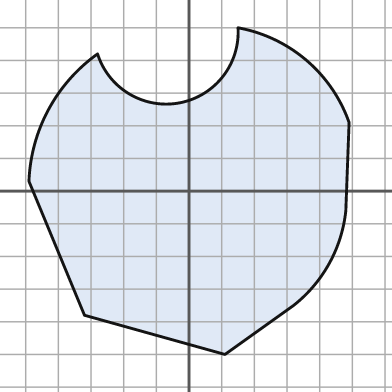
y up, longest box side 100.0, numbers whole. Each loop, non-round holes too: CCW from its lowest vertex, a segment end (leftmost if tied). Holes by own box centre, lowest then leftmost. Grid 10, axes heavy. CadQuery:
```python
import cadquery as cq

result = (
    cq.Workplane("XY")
    .moveTo(11.0, -50.0)
    .lineTo(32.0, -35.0)
    .threePointArc((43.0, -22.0), (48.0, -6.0))
    .lineTo(49.0, 21.0)
    .threePointArc((36.0, 40.0), (15.0, 50.0))
    .threePointArc((-3.0, 27.0), (-28.0, 42.0))
    .threePointArc((-43.0, 25.0), (-49.0, 3.0))
    .lineTo(-32.0, -38.0)
    .close()
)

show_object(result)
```